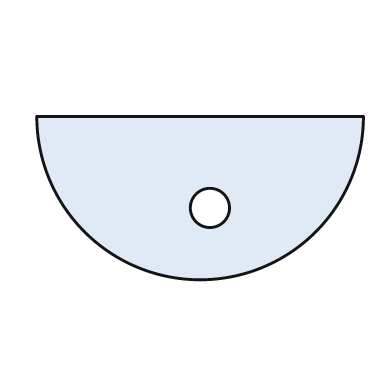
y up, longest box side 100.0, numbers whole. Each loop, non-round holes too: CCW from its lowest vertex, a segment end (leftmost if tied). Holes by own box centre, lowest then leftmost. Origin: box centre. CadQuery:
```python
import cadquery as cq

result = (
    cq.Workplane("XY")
    .moveTo(-50.0, 25.0)
    .threePointArc((0.0, -25.0), (50.0, 25.0))
    .close()
    .moveTo(3.0, -3.0)
    .circle(6.0)
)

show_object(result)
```